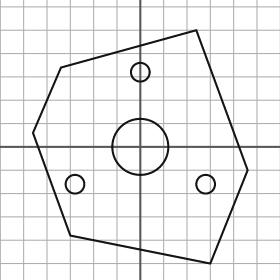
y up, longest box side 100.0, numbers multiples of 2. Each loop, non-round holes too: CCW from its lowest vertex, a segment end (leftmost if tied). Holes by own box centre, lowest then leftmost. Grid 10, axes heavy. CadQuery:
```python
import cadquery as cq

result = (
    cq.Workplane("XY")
    .moveTo(30.0, -50.0)
    .lineTo(46.0, -10.0)
    .lineTo(24.0, 50.0)
    .lineTo(-34.0, 34.0)
    .lineTo(-46.0, 6.0)
    .lineTo(-30.0, -38.0)
    .close()
    .moveTo(-28.0, -16.0)
    .circle(4.0)
    .moveTo(28.0, -16.0)
    .circle(4.0)
    .moveTo(0.0, 0.0)
    .circle(12.0)
    .moveTo(0.0, 32.0)
    .circle(4.0)
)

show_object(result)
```